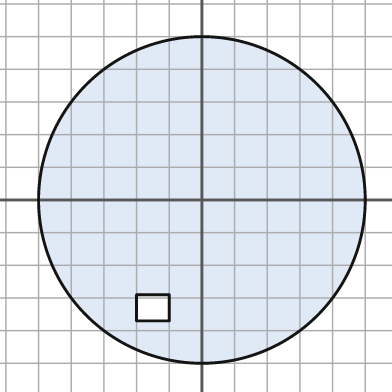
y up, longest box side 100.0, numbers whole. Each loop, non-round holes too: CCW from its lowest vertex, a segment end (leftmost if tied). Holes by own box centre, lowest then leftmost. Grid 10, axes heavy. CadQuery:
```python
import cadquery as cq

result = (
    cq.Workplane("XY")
    .moveTo(0.0, 0.0)
    .circle(50.0)
    .moveTo(-20.0, -37.0)
    .lineTo(-10.0, -37.0)
    .lineTo(-10.0, -29.0)
    .lineTo(-20.0, -29.0)
    .close()
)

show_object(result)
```